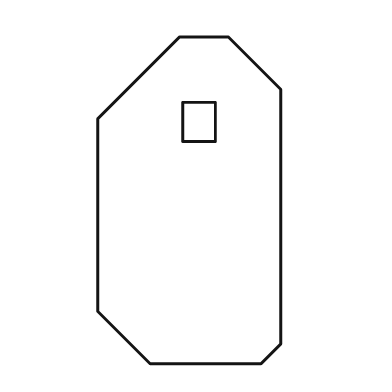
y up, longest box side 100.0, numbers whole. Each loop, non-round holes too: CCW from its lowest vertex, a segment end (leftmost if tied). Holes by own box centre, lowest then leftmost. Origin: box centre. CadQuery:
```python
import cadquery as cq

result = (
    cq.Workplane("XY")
    .moveTo(-12.0, -50.0)
    .lineTo(22.0, -50.0)
    .lineTo(28.0, -44.0)
    .lineTo(28.0, 34.0)
    .lineTo(12.0, 50.0)
    .lineTo(-3.0, 50.0)
    .lineTo(-28.0, 25.0)
    .lineTo(-28.0, -34.0)
    .close()
    .moveTo(-2.0, 18.0)
    .lineTo(8.0, 18.0)
    .lineTo(8.0, 30.0)
    .lineTo(-2.0, 30.0)
    .close()
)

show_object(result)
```